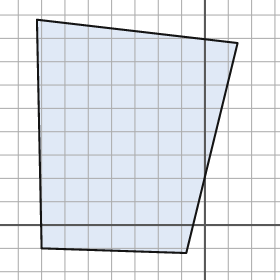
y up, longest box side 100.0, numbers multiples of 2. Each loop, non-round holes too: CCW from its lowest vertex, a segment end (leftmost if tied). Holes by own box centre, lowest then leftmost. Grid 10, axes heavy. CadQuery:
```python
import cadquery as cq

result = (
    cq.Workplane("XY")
    .moveTo(-8.0, -12.0)
    .lineTo(14.0, 78.0)
    .lineTo(-72.0, 88.0)
    .lineTo(-70.0, -10.0)
    .close()
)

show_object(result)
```